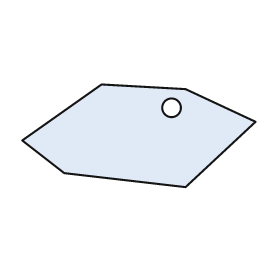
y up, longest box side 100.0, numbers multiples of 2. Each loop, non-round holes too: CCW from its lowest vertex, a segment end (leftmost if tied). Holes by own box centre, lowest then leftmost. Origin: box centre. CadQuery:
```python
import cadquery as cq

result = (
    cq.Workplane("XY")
    .moveTo(20.0, -22.0)
    .lineTo(50.0, 6.0)
    .lineTo(20.0, 20.0)
    .lineTo(-16.0, 22.0)
    .lineTo(-50.0, -2.0)
    .lineTo(-32.0, -16.0)
    .close()
    .moveTo(14.0, 12.0)
    .circle(4.0)
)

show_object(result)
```